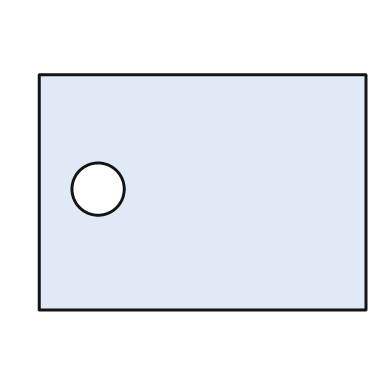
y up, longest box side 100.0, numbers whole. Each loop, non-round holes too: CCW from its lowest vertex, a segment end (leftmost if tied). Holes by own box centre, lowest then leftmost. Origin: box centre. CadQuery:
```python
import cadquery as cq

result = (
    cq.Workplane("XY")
    .moveTo(-50.0, -36.0)
    .lineTo(50.0, -36.0)
    .lineTo(50.0, 36.0)
    .lineTo(-50.0, 36.0)
    .close()
    .moveTo(-32.0, 1.0)
    .circle(8.0)
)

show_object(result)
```